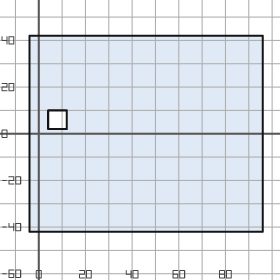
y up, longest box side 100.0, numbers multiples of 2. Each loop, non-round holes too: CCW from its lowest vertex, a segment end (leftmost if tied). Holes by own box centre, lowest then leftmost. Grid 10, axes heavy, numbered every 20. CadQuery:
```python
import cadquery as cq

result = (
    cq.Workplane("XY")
    .moveTo(-4.0, -42.0)
    .lineTo(96.0, -42.0)
    .lineTo(96.0, 42.0)
    .lineTo(-4.0, 42.0)
    .close()
    .moveTo(4.0, 2.0)
    .lineTo(12.0, 2.0)
    .lineTo(12.0, 10.0)
    .lineTo(4.0, 10.0)
    .close()
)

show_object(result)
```